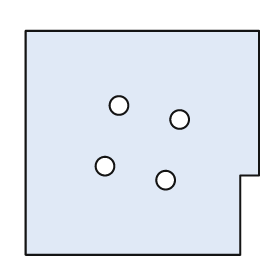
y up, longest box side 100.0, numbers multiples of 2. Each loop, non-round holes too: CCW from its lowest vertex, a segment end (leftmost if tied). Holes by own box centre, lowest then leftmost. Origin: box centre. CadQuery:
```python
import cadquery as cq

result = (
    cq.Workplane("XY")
    .moveTo(-50.0, -48.0)
    .lineTo(42.0, -48.0)
    .lineTo(42.0, -14.0)
    .lineTo(50.0, -14.0)
    .lineTo(50.0, 48.0)
    .lineTo(-50.0, 48.0)
    .close()
    .moveTo(10.0, -16.0)
    .circle(4.0)
    .moveTo(-16.0, -10.0)
    .circle(4.0)
    .moveTo(16.0, 10.0)
    .circle(4.0)
    .moveTo(-10.0, 16.0)
    .circle(4.0)
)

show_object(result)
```